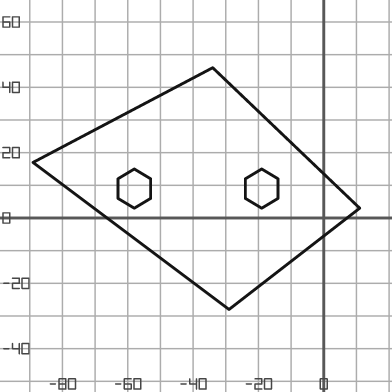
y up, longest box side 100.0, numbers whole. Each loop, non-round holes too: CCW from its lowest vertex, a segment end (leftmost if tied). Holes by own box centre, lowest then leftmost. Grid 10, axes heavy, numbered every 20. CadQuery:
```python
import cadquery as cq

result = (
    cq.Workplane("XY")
    .moveTo(-29.0, -28.0)
    .lineTo(11.0, 3.0)
    .lineTo(-34.0, 46.0)
    .lineTo(-89.0, 17.0)
    .close()
    .moveTo(-58.0, 3.0)
    .lineTo(-53.0, 6.0)
    .lineTo(-53.0, 12.0)
    .lineTo(-58.0, 15.0)
    .lineTo(-63.0, 12.0)
    .lineTo(-63.0, 6.0)
    .close()
    .moveTo(-19.0, 3.0)
    .lineTo(-14.0, 6.0)
    .lineTo(-14.0, 12.0)
    .lineTo(-19.0, 15.0)
    .lineTo(-24.0, 12.0)
    .lineTo(-24.0, 6.0)
    .close()
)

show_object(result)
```